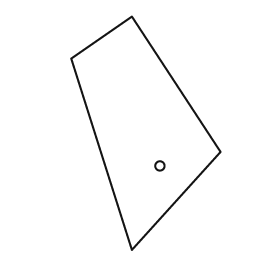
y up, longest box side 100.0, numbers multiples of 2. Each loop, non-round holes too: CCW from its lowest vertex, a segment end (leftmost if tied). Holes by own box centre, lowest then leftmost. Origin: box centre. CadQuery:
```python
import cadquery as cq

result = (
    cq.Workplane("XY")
    .moveTo(-6.0, -50.0)
    .lineTo(32.0, -8.0)
    .lineTo(-6.0, 50.0)
    .lineTo(-32.0, 32.0)
    .close()
    .moveTo(6.0, -14.0)
    .circle(2.0)
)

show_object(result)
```